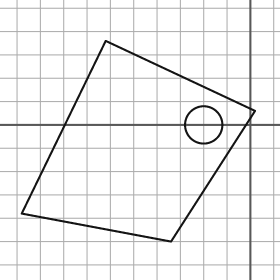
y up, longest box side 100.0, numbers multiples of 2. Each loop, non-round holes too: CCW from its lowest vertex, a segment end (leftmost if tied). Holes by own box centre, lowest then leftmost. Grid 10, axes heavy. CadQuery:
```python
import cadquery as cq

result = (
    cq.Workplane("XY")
    .moveTo(-34.0, -50.0)
    .lineTo(2.0, 6.0)
    .lineTo(-62.0, 36.0)
    .lineTo(-98.0, -38.0)
    .close()
    .moveTo(-20.0, 0.0)
    .circle(8.0)
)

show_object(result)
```